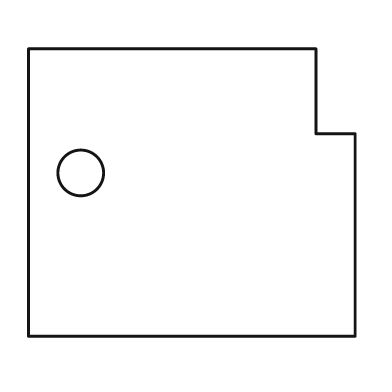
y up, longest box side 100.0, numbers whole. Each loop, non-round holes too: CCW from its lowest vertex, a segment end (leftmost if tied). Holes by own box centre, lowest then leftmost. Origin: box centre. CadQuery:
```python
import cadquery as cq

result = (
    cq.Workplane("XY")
    .moveTo(-50.0, -44.0)
    .lineTo(50.0, -44.0)
    .lineTo(50.0, 18.0)
    .lineTo(38.0, 18.0)
    .lineTo(38.0, 44.0)
    .lineTo(-50.0, 44.0)
    .close()
    .moveTo(-34.0, 6.0)
    .circle(7.0)
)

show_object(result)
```